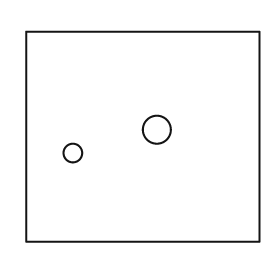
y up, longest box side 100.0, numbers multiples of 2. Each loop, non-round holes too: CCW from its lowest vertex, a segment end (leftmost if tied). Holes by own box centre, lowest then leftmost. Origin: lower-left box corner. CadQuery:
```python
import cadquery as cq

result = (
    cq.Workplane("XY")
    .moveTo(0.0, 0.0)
    .lineTo(100.0, 0.0)
    .lineTo(100.0, 90.0)
    .lineTo(0.0, 90.0)
    .close()
    .moveTo(20.0, 38.0)
    .circle(4.0)
    .moveTo(56.0, 48.0)
    .circle(6.0)
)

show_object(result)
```